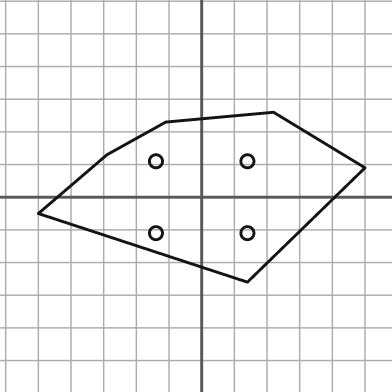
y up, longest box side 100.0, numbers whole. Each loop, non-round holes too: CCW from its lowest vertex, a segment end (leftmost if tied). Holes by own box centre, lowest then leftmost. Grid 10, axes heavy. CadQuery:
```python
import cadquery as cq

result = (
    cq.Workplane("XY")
    .moveTo(14.0, -26.0)
    .lineTo(50.0, 9.0)
    .lineTo(22.0, 26.0)
    .lineTo(-11.0, 23.0)
    .lineTo(-29.0, 13.0)
    .lineTo(-50.0, -5.0)
    .close()
    .moveTo(-14.0, -11.0)
    .circle(2.0)
    .moveTo(14.0, -11.0)
    .circle(2.0)
    .moveTo(-14.0, 11.0)
    .circle(2.0)
    .moveTo(14.0, 11.0)
    .circle(2.0)
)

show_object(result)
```